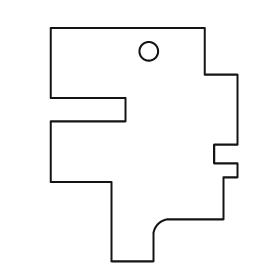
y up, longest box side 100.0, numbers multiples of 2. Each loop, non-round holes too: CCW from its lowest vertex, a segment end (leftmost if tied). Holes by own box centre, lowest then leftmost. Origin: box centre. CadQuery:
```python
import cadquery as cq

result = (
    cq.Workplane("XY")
    .moveTo(-14.0, -50.0)
    .lineTo(4.0, -50.0)
    .lineTo(4.0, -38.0)
    .threePointArc((6.0, -34.0), (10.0, -32.0))
    .lineTo(34.0, -32.0)
    .lineTo(34.0, -14.0)
    .lineTo(40.0, -14.0)
    .lineTo(40.0, -8.0)
    .lineTo(30.0, -8.0)
    .lineTo(30.0, 0.0)
    .lineTo(40.0, 0.0)
    .lineTo(40.0, 30.0)
    .lineTo(26.0, 30.0)
    .lineTo(26.0, 50.0)
    .lineTo(-40.0, 50.0)
    .lineTo(-40.0, 20.0)
    .lineTo(-8.0, 20.0)
    .lineTo(-8.0, 10.0)
    .lineTo(-40.0, 10.0)
    .lineTo(-40.0, -16.0)
    .lineTo(-14.0, -16.0)
    .close()
    .moveTo(2.0, 40.0)
    .circle(4.0)
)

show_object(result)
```